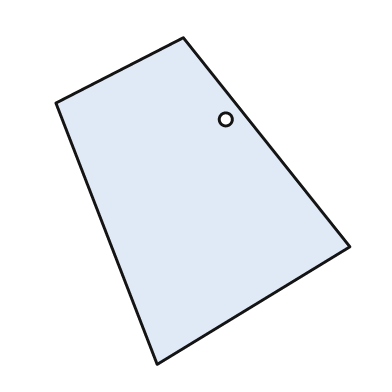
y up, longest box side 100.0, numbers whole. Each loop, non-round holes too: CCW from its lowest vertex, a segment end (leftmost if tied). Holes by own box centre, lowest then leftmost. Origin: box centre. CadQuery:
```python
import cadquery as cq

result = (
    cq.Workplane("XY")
    .moveTo(-14.0, -50.0)
    .lineTo(45.0, -14.0)
    .lineTo(-6.0, 50.0)
    .lineTo(-45.0, 30.0)
    .close()
    .moveTo(7.0, 25.0)
    .circle(2.0)
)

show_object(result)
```